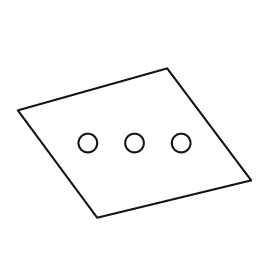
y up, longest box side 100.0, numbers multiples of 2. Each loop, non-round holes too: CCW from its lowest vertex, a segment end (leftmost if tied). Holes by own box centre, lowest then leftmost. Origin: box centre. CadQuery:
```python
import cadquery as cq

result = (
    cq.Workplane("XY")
    .moveTo(-16.0, -32.0)
    .lineTo(50.0, -16.0)
    .lineTo(14.0, 32.0)
    .lineTo(-50.0, 14.0)
    .close()
    .moveTo(-20.0, 0.0)
    .circle(4.0)
    .moveTo(0.0, 0.0)
    .circle(4.0)
    .moveTo(20.0, 0.0)
    .circle(4.0)
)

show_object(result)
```